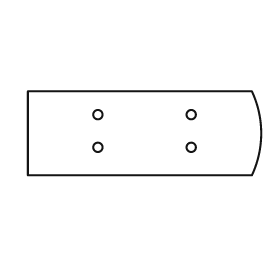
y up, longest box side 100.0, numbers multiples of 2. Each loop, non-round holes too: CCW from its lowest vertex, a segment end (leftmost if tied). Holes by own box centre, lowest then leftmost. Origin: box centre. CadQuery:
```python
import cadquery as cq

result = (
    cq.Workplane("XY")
    .moveTo(-50.0, -18.0)
    .lineTo(46.0, -18.0)
    .threePointArc((50.0, 0.0), (46.0, 18.0))
    .lineTo(-50.0, 18.0)
    .close()
    .moveTo(-20.0, -6.0)
    .circle(2.0)
    .moveTo(20.0, -6.0)
    .circle(2.0)
    .moveTo(-20.0, 8.0)
    .circle(2.0)
    .moveTo(20.0, 8.0)
    .circle(2.0)
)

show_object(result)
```